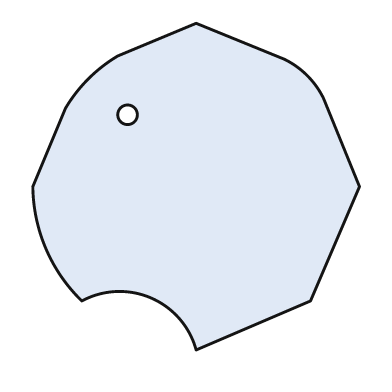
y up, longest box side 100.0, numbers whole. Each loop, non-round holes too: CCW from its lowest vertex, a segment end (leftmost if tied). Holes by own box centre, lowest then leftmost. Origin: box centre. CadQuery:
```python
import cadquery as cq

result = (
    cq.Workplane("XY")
    .moveTo(0.0, -50.0)
    .lineTo(35.0, -35.0)
    .lineTo(50.0, 0.0)
    .lineTo(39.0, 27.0)
    .threePointArc((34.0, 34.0), (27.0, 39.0))
    .lineTo(0.0, 50.0)
    .lineTo(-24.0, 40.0)
    .threePointArc((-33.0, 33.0), (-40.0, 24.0))
    .lineTo(-50.0, 0.0)
    .threePointArc((-46.0, -19.0), (-35.0, -35.0))
    .threePointArc((-14.0, -34.0), (0.0, -50.0))
    .close()
    .moveTo(-21.0, 22.0)
    .circle(3.0)
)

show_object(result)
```